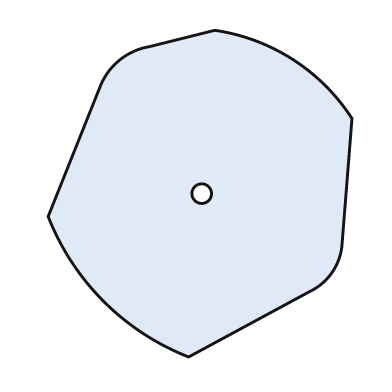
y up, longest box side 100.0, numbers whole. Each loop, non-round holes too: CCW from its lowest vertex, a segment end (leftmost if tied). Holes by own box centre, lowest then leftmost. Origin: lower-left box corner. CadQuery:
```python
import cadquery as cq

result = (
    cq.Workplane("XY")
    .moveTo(43.0, 0.0)
    .lineTo(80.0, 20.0)
    .threePointArc((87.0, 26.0), (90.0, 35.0))
    .lineTo(93.0, 73.0)
    .threePointArc((75.0, 91.0), (51.0, 100.0))
    .lineTo(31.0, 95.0)
    .threePointArc((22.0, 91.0), (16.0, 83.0))
    .lineTo(0.0, 43.0)
    .threePointArc((17.0, 17.0), (43.0, 0.0))
    .close()
    .moveTo(47.0, 50.0)
    .circle(3.0)
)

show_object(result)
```